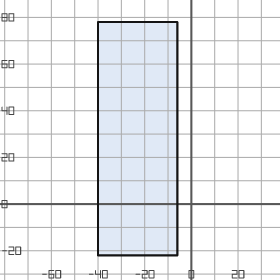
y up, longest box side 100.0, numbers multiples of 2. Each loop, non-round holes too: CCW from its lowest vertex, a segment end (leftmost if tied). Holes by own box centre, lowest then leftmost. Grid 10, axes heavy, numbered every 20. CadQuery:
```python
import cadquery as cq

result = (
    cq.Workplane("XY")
    .moveTo(-40.0, -22.0)
    .lineTo(-6.0, -22.0)
    .lineTo(-6.0, 78.0)
    .lineTo(-40.0, 78.0)
    .close()
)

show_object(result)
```